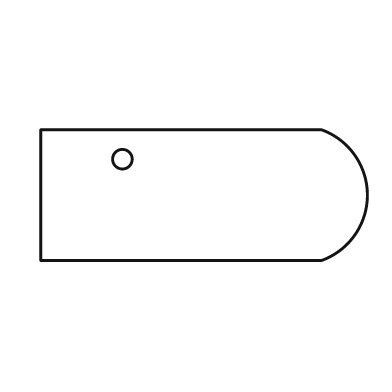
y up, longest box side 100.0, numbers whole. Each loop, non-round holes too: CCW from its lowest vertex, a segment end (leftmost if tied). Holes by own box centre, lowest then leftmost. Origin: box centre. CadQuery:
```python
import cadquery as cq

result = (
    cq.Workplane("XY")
    .moveTo(-50.0, -20.0)
    .lineTo(36.0, -20.0)
    .threePointArc((50.0, 0.0), (36.0, 20.0))
    .lineTo(-50.0, 20.0)
    .close()
    .moveTo(-25.0, 11.0)
    .circle(3.0)
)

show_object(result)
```